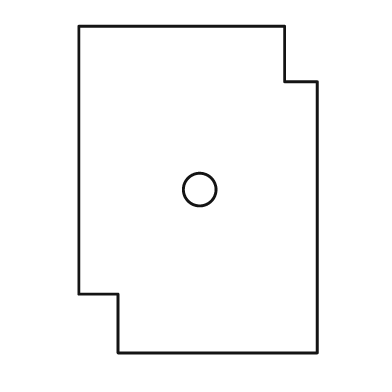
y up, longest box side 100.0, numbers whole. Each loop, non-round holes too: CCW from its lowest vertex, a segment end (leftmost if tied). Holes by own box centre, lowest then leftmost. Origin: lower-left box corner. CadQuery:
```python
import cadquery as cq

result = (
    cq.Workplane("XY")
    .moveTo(12.0, 0.0)
    .lineTo(73.0, 0.0)
    .lineTo(73.0, 83.0)
    .lineTo(63.0, 83.0)
    .lineTo(63.0, 100.0)
    .lineTo(0.0, 100.0)
    .lineTo(0.0, 18.0)
    .lineTo(12.0, 18.0)
    .close()
    .moveTo(37.0, 50.0)
    .circle(5.0)
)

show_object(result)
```